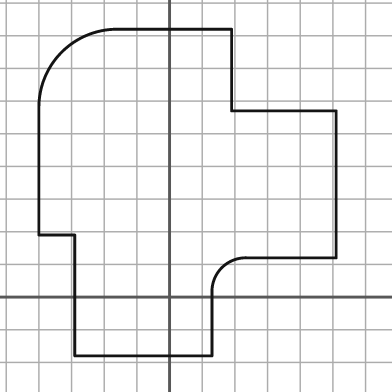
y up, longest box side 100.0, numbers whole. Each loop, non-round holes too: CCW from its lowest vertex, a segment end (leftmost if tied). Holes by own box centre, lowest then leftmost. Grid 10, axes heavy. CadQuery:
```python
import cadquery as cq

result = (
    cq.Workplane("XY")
    .moveTo(-29.0, -18.0)
    .lineTo(13.0, -18.0)
    .lineTo(13.0, 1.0)
    .threePointArc((16.0, 9.0), (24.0, 12.0))
    .lineTo(51.0, 12.0)
    .lineTo(51.0, 57.0)
    .lineTo(19.0, 57.0)
    .lineTo(19.0, 82.0)
    .lineTo(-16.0, 82.0)
    .threePointArc((-33.0, 75.0), (-40.0, 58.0))
    .lineTo(-40.0, 19.0)
    .lineTo(-29.0, 19.0)
    .close()
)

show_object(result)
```